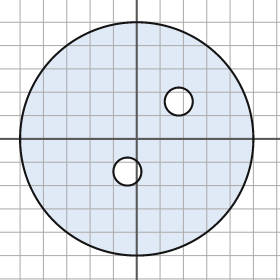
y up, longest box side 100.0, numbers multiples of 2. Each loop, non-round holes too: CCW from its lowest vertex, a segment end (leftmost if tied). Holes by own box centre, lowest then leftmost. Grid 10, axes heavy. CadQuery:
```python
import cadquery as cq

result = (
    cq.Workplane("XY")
    .moveTo(0.0, 0.0)
    .circle(50.0)
    .moveTo(-4.0, -14.0)
    .circle(6.0)
    .moveTo(18.0, 16.0)
    .circle(6.0)
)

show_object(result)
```